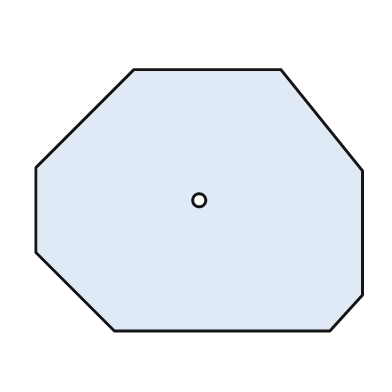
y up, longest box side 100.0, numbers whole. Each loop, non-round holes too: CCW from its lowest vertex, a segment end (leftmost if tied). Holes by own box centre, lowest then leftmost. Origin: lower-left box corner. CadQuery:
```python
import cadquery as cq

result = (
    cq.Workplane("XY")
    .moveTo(24.0, 0.0)
    .lineTo(90.0, 0.0)
    .lineTo(100.0, 11.0)
    .lineTo(100.0, 49.0)
    .lineTo(75.0, 80.0)
    .lineTo(30.0, 80.0)
    .lineTo(0.0, 50.0)
    .lineTo(0.0, 24.0)
    .close()
    .moveTo(50.0, 40.0)
    .circle(2.0)
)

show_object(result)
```